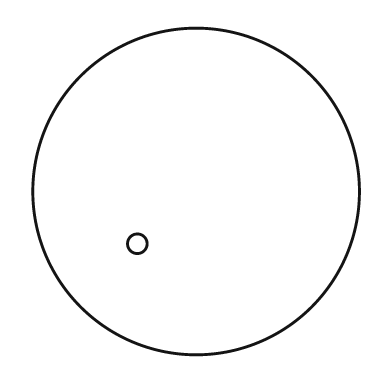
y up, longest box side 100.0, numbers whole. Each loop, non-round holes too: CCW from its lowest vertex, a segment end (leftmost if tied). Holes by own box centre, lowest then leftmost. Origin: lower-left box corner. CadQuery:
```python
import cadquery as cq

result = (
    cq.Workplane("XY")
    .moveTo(50.0, 50.0)
    .circle(50.0)
    .moveTo(32.0, 34.0)
    .circle(3.0)
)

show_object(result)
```